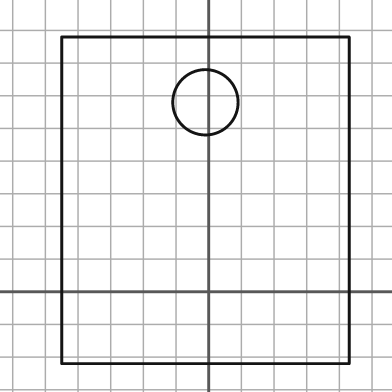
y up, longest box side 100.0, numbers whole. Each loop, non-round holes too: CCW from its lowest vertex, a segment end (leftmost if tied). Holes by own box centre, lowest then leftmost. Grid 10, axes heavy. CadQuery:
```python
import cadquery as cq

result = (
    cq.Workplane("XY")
    .moveTo(-45.0, -22.0)
    .lineTo(43.0, -22.0)
    .lineTo(43.0, 78.0)
    .lineTo(-45.0, 78.0)
    .close()
    .moveTo(-1.0, 58.0)
    .circle(10.0)
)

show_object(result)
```